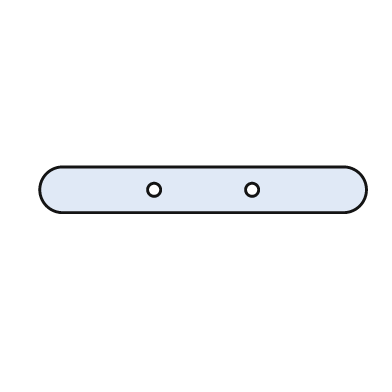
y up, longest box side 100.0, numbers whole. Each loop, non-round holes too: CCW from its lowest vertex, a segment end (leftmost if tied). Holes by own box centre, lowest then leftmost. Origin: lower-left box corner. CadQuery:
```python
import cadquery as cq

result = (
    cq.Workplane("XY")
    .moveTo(7.0, 0.0)
    .lineTo(93.0, 0.0)
    .threePointArc((100.0, 7.0), (93.0, 14.0))
    .lineTo(7.0, 14.0)
    .threePointArc((0.0, 7.0), (7.0, 0.0))
    .close()
    .moveTo(35.0, 7.0)
    .circle(2.0)
    .moveTo(65.0, 7.0)
    .circle(2.0)
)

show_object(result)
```